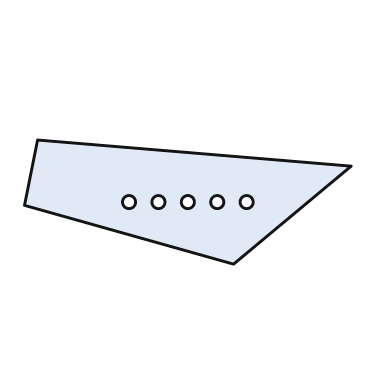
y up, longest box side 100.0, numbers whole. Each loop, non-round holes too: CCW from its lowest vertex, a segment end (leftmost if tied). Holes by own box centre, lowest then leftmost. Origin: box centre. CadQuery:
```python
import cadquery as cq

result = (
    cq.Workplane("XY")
    .moveTo(14.0, -19.0)
    .lineTo(50.0, 11.0)
    .lineTo(-46.0, 19.0)
    .lineTo(-50.0, -1.0)
    .close()
    .moveTo(-18.0, 0.0)
    .circle(2.0)
    .moveTo(-9.0, 0.0)
    .circle(2.0)
    .moveTo(0.0, 0.0)
    .circle(2.0)
    .moveTo(9.0, 0.0)
    .circle(2.0)
    .moveTo(18.0, 0.0)
    .circle(2.0)
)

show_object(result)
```